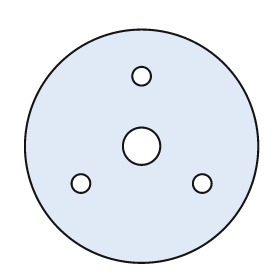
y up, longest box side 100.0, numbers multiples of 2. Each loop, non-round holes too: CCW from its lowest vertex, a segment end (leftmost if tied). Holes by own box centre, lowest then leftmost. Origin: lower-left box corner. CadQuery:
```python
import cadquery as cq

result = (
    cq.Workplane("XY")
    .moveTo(50.0, 50.0)
    .circle(50.0)
    .moveTo(24.0, 34.0)
    .circle(4.0)
    .moveTo(76.0, 34.0)
    .circle(4.0)
    .moveTo(50.0, 50.0)
    .circle(8.0)
    .moveTo(50.0, 80.0)
    .circle(4.0)
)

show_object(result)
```